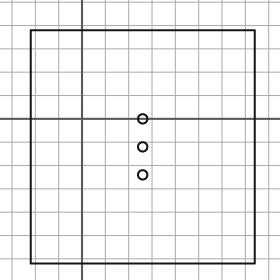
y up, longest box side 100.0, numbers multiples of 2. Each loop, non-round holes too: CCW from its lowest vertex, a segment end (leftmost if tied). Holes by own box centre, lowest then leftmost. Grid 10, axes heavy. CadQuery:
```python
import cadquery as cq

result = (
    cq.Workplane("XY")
    .moveTo(-22.0, -62.0)
    .lineTo(74.0, -62.0)
    .lineTo(74.0, 38.0)
    .lineTo(-22.0, 38.0)
    .close()
    .moveTo(26.0, -24.0)
    .circle(2.0)
    .moveTo(26.0, -12.0)
    .circle(2.0)
    .moveTo(26.0, 0.0)
    .circle(2.0)
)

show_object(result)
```